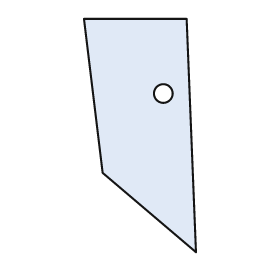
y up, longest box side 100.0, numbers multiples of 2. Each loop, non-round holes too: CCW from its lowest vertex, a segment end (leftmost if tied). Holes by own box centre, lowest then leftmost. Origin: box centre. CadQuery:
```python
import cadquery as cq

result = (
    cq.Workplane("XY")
    .moveTo(24.0, -50.0)
    .lineTo(20.0, 50.0)
    .lineTo(-24.0, 50.0)
    .lineTo(-16.0, -16.0)
    .close()
    .moveTo(10.0, 18.0)
    .circle(4.0)
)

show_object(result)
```